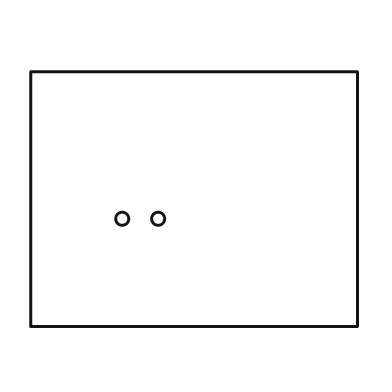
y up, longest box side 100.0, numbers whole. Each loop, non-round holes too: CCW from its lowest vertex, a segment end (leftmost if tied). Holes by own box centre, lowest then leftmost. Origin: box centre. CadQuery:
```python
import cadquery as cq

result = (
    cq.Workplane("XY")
    .moveTo(-50.0, -39.0)
    .lineTo(50.0, -39.0)
    .lineTo(50.0, 39.0)
    .lineTo(-50.0, 39.0)
    .close()
    .moveTo(-22.0, -6.0)
    .circle(2.0)
    .moveTo(-11.0, -6.0)
    .circle(2.0)
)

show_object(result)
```